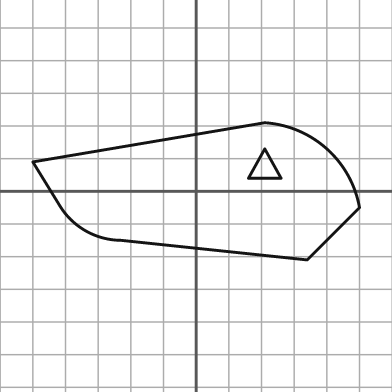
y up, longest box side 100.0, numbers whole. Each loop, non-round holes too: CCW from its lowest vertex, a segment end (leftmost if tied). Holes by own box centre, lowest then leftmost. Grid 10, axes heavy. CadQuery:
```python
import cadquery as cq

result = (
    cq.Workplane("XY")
    .moveTo(34.0, -21.0)
    .lineTo(50.0, -5.0)
    .threePointArc((40.0, 13.0), (21.0, 21.0))
    .lineTo(-50.0, 9.0)
    .lineTo(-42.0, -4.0)
    .threePointArc((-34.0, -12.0), (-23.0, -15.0))
    .close()
    .moveTo(16.0, 4.0)
    .lineTo(26.0, 4.0)
    .lineTo(21.0, 13.0)
    .close()
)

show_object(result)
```